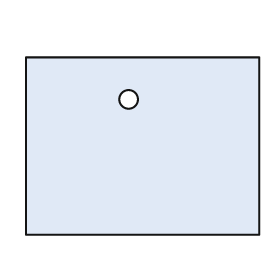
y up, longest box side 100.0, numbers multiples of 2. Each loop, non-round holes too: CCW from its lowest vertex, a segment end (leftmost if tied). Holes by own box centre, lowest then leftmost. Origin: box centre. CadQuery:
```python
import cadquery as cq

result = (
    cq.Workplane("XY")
    .moveTo(-50.0, -38.0)
    .lineTo(50.0, -38.0)
    .lineTo(50.0, 38.0)
    .lineTo(-50.0, 38.0)
    .close()
    .moveTo(-6.0, 20.0)
    .circle(4.0)
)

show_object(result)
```